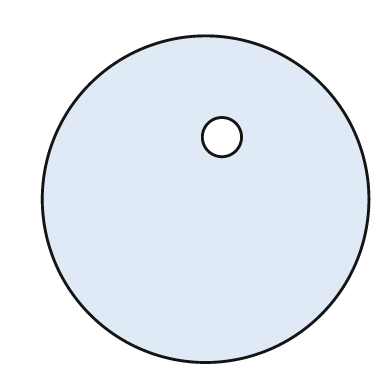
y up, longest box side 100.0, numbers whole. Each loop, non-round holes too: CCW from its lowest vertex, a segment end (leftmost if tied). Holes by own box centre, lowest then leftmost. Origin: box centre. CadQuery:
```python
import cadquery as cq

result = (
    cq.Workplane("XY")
    .moveTo(0.0, 0.0)
    .circle(50.0)
    .moveTo(5.0, 19.0)
    .circle(6.0)
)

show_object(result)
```